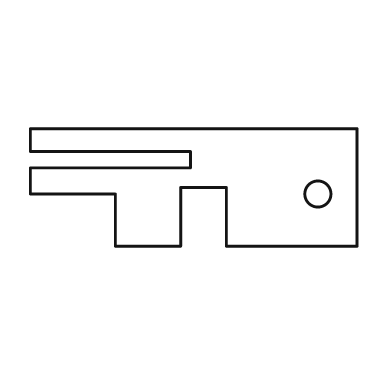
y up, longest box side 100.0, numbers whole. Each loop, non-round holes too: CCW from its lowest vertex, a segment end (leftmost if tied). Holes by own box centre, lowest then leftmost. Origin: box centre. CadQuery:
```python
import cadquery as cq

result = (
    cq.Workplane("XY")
    .moveTo(-24.0, -18.0)
    .lineTo(-4.0, -18.0)
    .lineTo(-4.0, 0.0)
    .lineTo(10.0, 0.0)
    .lineTo(10.0, -18.0)
    .lineTo(50.0, -18.0)
    .lineTo(50.0, 18.0)
    .lineTo(-50.0, 18.0)
    .lineTo(-50.0, 11.0)
    .lineTo(-1.0, 11.0)
    .lineTo(-1.0, 6.0)
    .lineTo(-50.0, 6.0)
    .lineTo(-50.0, -2.0)
    .lineTo(-24.0, -2.0)
    .close()
    .moveTo(38.0, -2.0)
    .circle(4.0)
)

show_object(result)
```